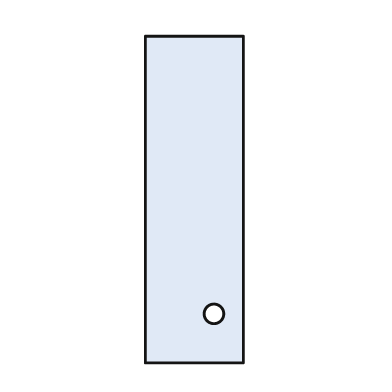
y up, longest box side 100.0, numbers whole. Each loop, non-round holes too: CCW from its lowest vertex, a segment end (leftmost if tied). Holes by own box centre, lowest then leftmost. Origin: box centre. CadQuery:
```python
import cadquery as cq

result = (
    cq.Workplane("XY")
    .moveTo(-15.0, -50.0)
    .lineTo(15.0, -50.0)
    .lineTo(15.0, 50.0)
    .lineTo(-15.0, 50.0)
    .close()
    .moveTo(6.0, -35.0)
    .circle(3.0)
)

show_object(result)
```